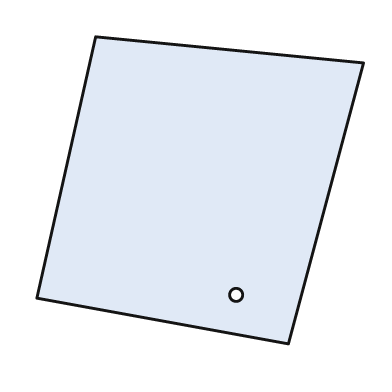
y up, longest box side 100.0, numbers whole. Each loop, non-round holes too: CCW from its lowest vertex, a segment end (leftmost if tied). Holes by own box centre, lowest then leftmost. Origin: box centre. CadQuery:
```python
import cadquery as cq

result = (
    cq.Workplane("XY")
    .moveTo(27.0, -47.0)
    .lineTo(50.0, 39.0)
    .lineTo(-32.0, 47.0)
    .lineTo(-50.0, -33.0)
    .close()
    .moveTo(11.0, -32.0)
    .circle(2.0)
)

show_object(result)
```